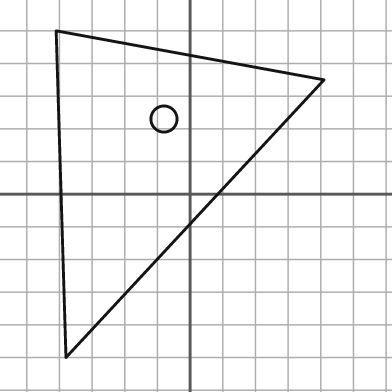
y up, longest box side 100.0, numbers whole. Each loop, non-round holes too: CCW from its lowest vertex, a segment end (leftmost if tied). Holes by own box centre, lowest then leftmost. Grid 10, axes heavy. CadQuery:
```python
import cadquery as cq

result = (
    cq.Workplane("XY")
    .moveTo(-38.0, -50.0)
    .lineTo(41.0, 35.0)
    .lineTo(-41.0, 50.0)
    .close()
    .moveTo(-8.0, 23.0)
    .circle(4.0)
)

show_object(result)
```